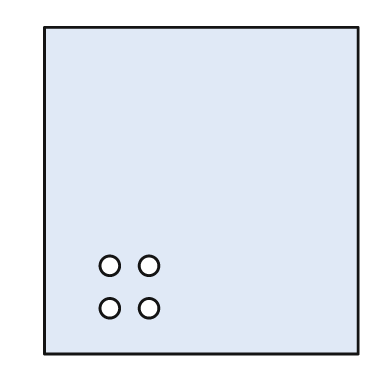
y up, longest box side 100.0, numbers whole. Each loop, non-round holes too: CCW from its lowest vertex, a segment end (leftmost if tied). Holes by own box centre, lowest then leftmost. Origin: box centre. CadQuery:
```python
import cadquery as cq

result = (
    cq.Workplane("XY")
    .moveTo(-48.0, -50.0)
    .lineTo(48.0, -50.0)
    .lineTo(48.0, 50.0)
    .lineTo(-48.0, 50.0)
    .close()
    .moveTo(-28.0, -36.0)
    .circle(3.0)
    .moveTo(-16.0, -36.0)
    .circle(3.0)
    .moveTo(-28.0, -23.0)
    .circle(3.0)
    .moveTo(-16.0, -23.0)
    .circle(3.0)
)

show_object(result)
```